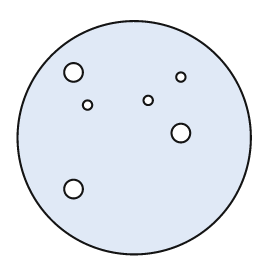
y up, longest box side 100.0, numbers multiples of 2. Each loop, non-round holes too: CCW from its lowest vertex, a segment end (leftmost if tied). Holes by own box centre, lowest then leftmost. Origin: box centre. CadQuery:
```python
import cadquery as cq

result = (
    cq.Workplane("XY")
    .moveTo(0.0, 0.0)
    .circle(50.0)
    .moveTo(-26.0, -22.0)
    .circle(4.0)
    .moveTo(20.0, 2.0)
    .circle(4.0)
    .moveTo(-20.0, 14.0)
    .circle(2.0)
    .moveTo(6.0, 16.0)
    .circle(2.0)
    .moveTo(20.0, 26.0)
    .circle(2.0)
    .moveTo(-26.0, 28.0)
    .circle(4.0)
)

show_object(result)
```